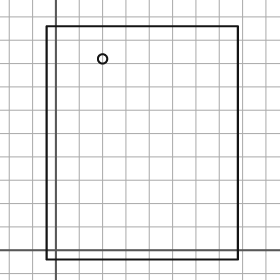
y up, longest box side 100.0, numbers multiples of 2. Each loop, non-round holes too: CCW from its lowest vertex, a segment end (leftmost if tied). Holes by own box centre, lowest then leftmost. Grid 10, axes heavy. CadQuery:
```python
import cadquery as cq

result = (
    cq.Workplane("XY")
    .moveTo(-4.0, -4.0)
    .lineTo(78.0, -4.0)
    .lineTo(78.0, 96.0)
    .lineTo(-4.0, 96.0)
    .close()
    .moveTo(20.0, 82.0)
    .circle(2.0)
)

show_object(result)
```